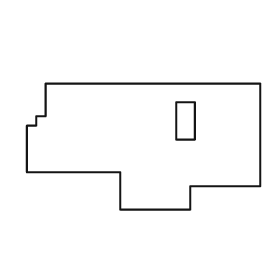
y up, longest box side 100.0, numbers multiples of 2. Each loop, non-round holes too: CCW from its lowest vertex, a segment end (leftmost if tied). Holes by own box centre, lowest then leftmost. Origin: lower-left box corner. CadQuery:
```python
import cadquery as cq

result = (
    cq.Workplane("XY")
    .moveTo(40.0, 0.0)
    .lineTo(70.0, 0.0)
    .lineTo(70.0, 10.0)
    .lineTo(100.0, 10.0)
    .lineTo(100.0, 54.0)
    .lineTo(8.0, 54.0)
    .lineTo(8.0, 40.0)
    .lineTo(4.0, 40.0)
    .lineTo(4.0, 36.0)
    .lineTo(0.0, 36.0)
    .lineTo(0.0, 16.0)
    .lineTo(40.0, 16.0)
    .close()
    .moveTo(64.0, 30.0)
    .lineTo(72.0, 30.0)
    .lineTo(72.0, 46.0)
    .lineTo(64.0, 46.0)
    .close()
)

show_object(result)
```